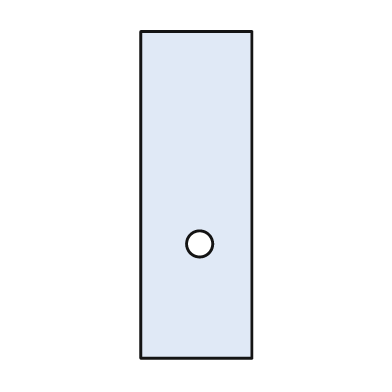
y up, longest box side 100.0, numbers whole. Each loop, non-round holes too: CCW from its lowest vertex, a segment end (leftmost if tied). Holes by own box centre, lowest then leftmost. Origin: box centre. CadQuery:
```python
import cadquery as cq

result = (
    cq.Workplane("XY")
    .moveTo(-17.0, -50.0)
    .lineTo(17.0, -50.0)
    .lineTo(17.0, 50.0)
    .lineTo(-17.0, 50.0)
    .close()
    .moveTo(1.0, -15.0)
    .circle(4.0)
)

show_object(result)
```